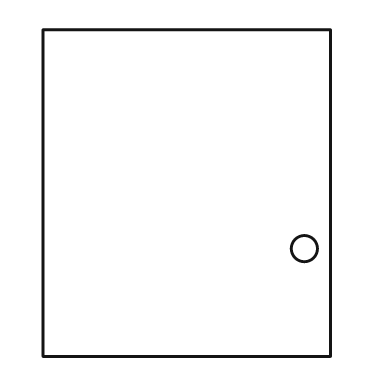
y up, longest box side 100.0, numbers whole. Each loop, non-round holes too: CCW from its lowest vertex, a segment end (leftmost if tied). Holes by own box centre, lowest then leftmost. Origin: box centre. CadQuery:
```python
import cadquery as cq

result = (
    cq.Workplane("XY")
    .moveTo(-44.0, -50.0)
    .lineTo(44.0, -50.0)
    .lineTo(44.0, 50.0)
    .lineTo(-44.0, 50.0)
    .close()
    .moveTo(36.0, -17.0)
    .circle(4.0)
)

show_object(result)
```